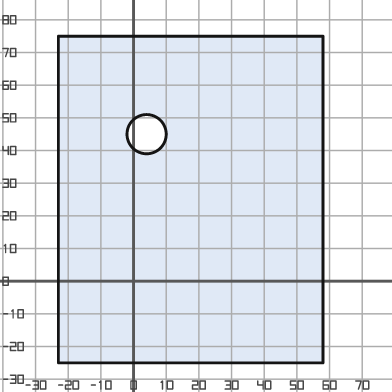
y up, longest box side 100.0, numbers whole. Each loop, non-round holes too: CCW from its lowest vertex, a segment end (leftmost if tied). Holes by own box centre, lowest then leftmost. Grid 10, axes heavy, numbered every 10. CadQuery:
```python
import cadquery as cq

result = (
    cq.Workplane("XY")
    .moveTo(-23.0, -25.0)
    .lineTo(58.0, -25.0)
    .lineTo(58.0, 75.0)
    .lineTo(-23.0, 75.0)
    .close()
    .moveTo(4.0, 45.0)
    .circle(6.0)
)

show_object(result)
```